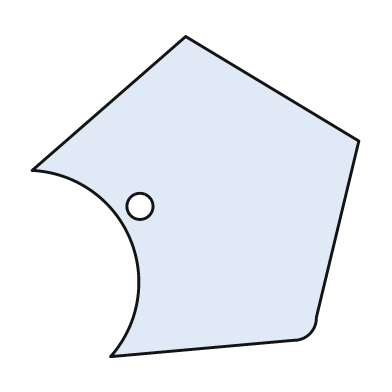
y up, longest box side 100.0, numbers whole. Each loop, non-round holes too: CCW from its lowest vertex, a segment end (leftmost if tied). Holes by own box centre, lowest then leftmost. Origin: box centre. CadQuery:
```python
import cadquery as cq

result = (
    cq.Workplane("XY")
    .moveTo(-26.0, -49.0)
    .lineTo(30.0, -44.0)
    .threePointArc((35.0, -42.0), (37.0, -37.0))
    .lineTo(50.0, 17.0)
    .lineTo(-3.0, 49.0)
    .lineTo(-50.0, 8.0)
    .threePointArc((-20.0, -13.0), (-26.0, -49.0))
    .close()
    .moveTo(-17.0, -3.0)
    .circle(4.0)
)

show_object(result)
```